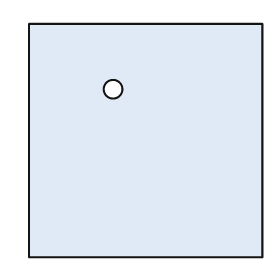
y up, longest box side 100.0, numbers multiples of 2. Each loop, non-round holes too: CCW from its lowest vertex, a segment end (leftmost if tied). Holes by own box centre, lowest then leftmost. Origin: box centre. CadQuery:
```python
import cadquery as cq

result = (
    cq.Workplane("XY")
    .moveTo(-50.0, -50.0)
    .lineTo(50.0, -50.0)
    .lineTo(50.0, 50.0)
    .lineTo(-50.0, 50.0)
    .close()
    .moveTo(-14.0, 22.0)
    .circle(4.0)
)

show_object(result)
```